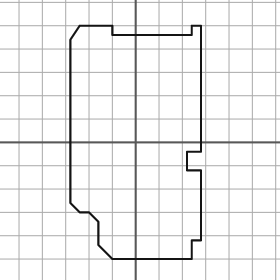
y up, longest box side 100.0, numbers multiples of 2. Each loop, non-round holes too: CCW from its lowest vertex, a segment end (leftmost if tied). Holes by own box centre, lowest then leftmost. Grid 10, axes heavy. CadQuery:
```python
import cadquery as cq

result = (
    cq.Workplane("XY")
    .moveTo(-10.0, -50.0)
    .lineTo(24.0, -50.0)
    .lineTo(24.0, -42.0)
    .lineTo(28.0, -42.0)
    .lineTo(28.0, -12.0)
    .lineTo(22.0, -12.0)
    .lineTo(22.0, -4.0)
    .lineTo(28.0, -4.0)
    .lineTo(28.0, 50.0)
    .lineTo(24.0, 50.0)
    .lineTo(24.0, 46.0)
    .lineTo(-10.0, 46.0)
    .lineTo(-10.0, 50.0)
    .lineTo(-24.0, 50.0)
    .lineTo(-28.0, 44.0)
    .lineTo(-28.0, -26.0)
    .lineTo(-24.0, -30.0)
    .lineTo(-20.0, -30.0)
    .lineTo(-16.0, -34.0)
    .lineTo(-16.0, -44.0)
    .close()
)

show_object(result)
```